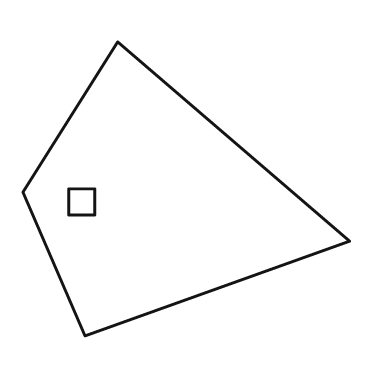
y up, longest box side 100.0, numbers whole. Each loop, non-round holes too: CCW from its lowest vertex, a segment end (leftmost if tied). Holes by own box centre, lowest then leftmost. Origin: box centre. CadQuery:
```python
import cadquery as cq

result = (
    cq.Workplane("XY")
    .moveTo(-31.0, -45.0)
    .lineTo(50.0, -16.0)
    .lineTo(-21.0, 45.0)
    .lineTo(-50.0, -1.0)
    .close()
    .moveTo(-36.0, -8.0)
    .lineTo(-28.0, -8.0)
    .lineTo(-28.0, 0.0)
    .lineTo(-36.0, 0.0)
    .close()
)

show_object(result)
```